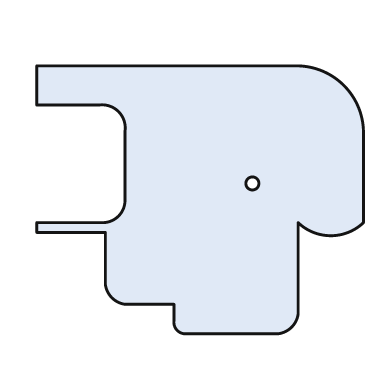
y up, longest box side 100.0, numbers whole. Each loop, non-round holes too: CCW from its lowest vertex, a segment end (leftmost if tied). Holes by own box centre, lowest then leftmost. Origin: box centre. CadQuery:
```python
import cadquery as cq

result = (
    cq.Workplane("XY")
    .moveTo(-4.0, -41.0)
    .lineTo(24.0, -41.0)
    .threePointArc((28.0, -39.0), (30.0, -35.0))
    .lineTo(30.0, -7.0)
    .threePointArc((40.0, -11.0), (50.0, -7.0))
    .lineTo(50.0, 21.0)
    .threePointArc((44.0, 35.0), (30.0, 41.0))
    .lineTo(-50.0, 41.0)
    .lineTo(-50.0, 29.0)
    .lineTo(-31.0, 29.0)
    .threePointArc((-25.0, 27.0), (-23.0, 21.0))
    .lineTo(-23.0, 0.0)
    .threePointArc((-25.0, -5.0), (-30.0, -7.0))
    .lineTo(-50.0, -7.0)
    .lineTo(-50.0, -10.0)
    .lineTo(-29.0, -10.0)
    .lineTo(-29.0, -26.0)
    .threePointArc((-27.0, -30.0), (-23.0, -32.0))
    .lineTo(-8.0, -32.0)
    .lineTo(-8.0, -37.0)
    .threePointArc((-7.0, -40.0), (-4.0, -41.0))
    .close()
    .moveTo(16.0, 5.0)
    .circle(2.0)
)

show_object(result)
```